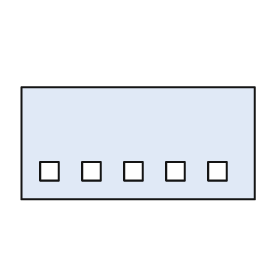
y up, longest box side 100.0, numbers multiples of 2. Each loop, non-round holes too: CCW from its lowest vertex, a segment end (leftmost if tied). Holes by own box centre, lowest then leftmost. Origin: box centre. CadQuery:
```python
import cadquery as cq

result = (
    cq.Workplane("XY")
    .moveTo(-50.0, -24.0)
    .lineTo(50.0, -24.0)
    .lineTo(50.0, 24.0)
    .lineTo(-50.0, 24.0)
    .close()
    .moveTo(-42.0, -16.0)
    .lineTo(-34.0, -16.0)
    .lineTo(-34.0, -8.0)
    .lineTo(-42.0, -8.0)
    .close()
    .moveTo(-24.0, -16.0)
    .lineTo(-16.0, -16.0)
    .lineTo(-16.0, -8.0)
    .lineTo(-24.0, -8.0)
    .close()
    .moveTo(-6.0, -16.0)
    .lineTo(2.0, -16.0)
    .lineTo(2.0, -8.0)
    .lineTo(-6.0, -8.0)
    .close()
    .moveTo(12.0, -16.0)
    .lineTo(20.0, -16.0)
    .lineTo(20.0, -8.0)
    .lineTo(12.0, -8.0)
    .close()
    .moveTo(30.0, -16.0)
    .lineTo(38.0, -16.0)
    .lineTo(38.0, -8.0)
    .lineTo(30.0, -8.0)
    .close()
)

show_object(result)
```